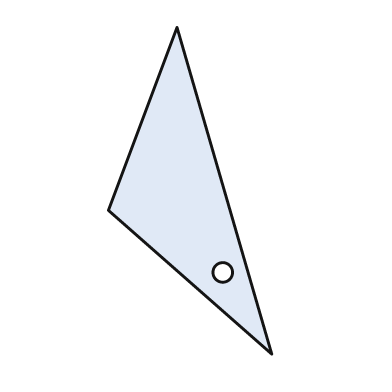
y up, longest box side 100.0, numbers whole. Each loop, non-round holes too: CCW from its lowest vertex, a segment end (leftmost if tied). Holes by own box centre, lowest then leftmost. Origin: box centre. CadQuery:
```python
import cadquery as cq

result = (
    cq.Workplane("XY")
    .moveTo(25.0, -50.0)
    .lineTo(-4.0, 50.0)
    .lineTo(-25.0, -6.0)
    .close()
    .moveTo(10.0, -25.0)
    .circle(3.0)
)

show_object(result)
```